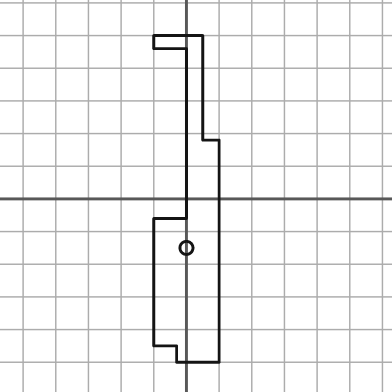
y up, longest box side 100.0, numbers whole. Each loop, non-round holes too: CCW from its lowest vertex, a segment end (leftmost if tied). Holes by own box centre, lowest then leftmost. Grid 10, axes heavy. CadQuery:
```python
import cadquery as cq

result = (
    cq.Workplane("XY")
    .moveTo(-3.0, -50.0)
    .lineTo(10.0, -50.0)
    .lineTo(10.0, 18.0)
    .lineTo(5.0, 18.0)
    .lineTo(5.0, 50.0)
    .lineTo(-10.0, 50.0)
    .lineTo(-10.0, 46.0)
    .lineTo(0.0, 46.0)
    .lineTo(0.0, -6.0)
    .lineTo(-10.0, -6.0)
    .lineTo(-10.0, -45.0)
    .lineTo(-3.0, -45.0)
    .close()
    .moveTo(0.0, -15.0)
    .circle(2.0)
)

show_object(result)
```